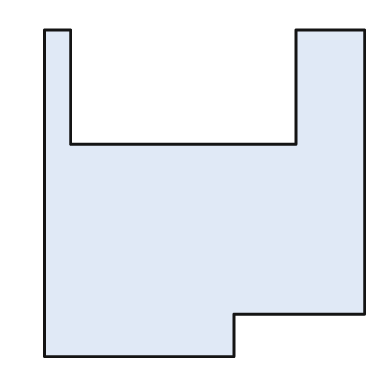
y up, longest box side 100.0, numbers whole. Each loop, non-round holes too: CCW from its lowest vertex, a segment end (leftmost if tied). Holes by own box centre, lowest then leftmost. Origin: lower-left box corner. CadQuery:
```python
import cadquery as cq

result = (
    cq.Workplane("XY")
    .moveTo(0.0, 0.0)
    .lineTo(58.0, 0.0)
    .lineTo(58.0, 13.0)
    .lineTo(98.0, 13.0)
    .lineTo(98.0, 100.0)
    .lineTo(77.0, 100.0)
    .lineTo(77.0, 65.0)
    .lineTo(8.0, 65.0)
    .lineTo(8.0, 100.0)
    .lineTo(0.0, 100.0)
    .close()
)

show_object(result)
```